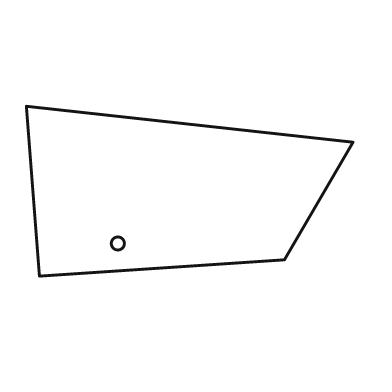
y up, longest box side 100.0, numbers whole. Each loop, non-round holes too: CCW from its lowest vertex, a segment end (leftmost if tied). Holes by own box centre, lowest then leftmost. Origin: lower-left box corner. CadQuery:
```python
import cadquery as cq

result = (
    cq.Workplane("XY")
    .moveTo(4.0, 0.0)
    .lineTo(79.0, 5.0)
    .lineTo(100.0, 41.0)
    .lineTo(0.0, 52.0)
    .close()
    .moveTo(28.0, 10.0)
    .circle(2.0)
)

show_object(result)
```